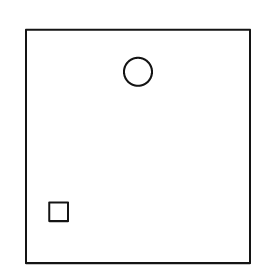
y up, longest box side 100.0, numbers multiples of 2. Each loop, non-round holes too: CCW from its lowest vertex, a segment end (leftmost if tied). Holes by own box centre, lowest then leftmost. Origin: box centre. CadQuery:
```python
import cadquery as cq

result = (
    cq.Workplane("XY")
    .moveTo(-48.0, -50.0)
    .lineTo(48.0, -50.0)
    .lineTo(48.0, 50.0)
    .lineTo(-48.0, 50.0)
    .close()
    .moveTo(-38.0, -32.0)
    .lineTo(-30.0, -32.0)
    .lineTo(-30.0, -24.0)
    .lineTo(-38.0, -24.0)
    .close()
    .moveTo(0.0, 32.0)
    .circle(6.0)
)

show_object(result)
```